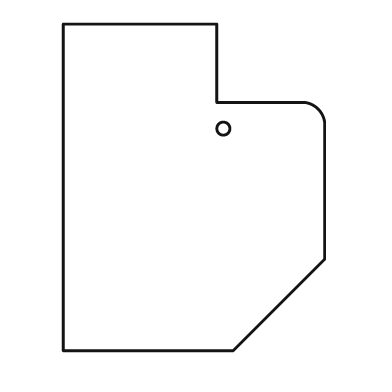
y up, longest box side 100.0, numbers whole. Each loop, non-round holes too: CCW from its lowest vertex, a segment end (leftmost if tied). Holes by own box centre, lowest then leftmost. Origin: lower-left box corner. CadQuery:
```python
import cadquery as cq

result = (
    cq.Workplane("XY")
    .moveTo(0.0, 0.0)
    .lineTo(52.0, 0.0)
    .lineTo(80.0, 28.0)
    .lineTo(80.0, 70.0)
    .threePointArc((78.0, 74.0), (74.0, 76.0))
    .lineTo(47.0, 76.0)
    .lineTo(47.0, 100.0)
    .lineTo(0.0, 100.0)
    .close()
    .moveTo(49.0, 68.0)
    .circle(2.0)
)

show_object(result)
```